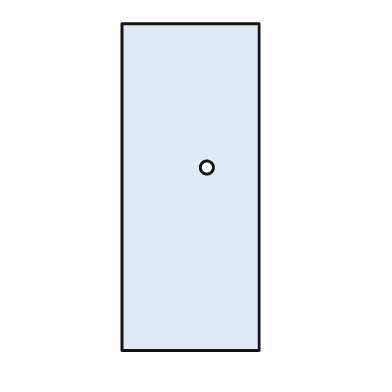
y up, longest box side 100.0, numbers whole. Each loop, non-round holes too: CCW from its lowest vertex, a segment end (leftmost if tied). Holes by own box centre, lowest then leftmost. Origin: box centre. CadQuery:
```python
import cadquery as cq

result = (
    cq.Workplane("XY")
    .moveTo(-21.0, -50.0)
    .lineTo(21.0, -50.0)
    .lineTo(21.0, 50.0)
    .lineTo(-21.0, 50.0)
    .close()
    .moveTo(5.0, 6.0)
    .circle(2.0)
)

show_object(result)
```